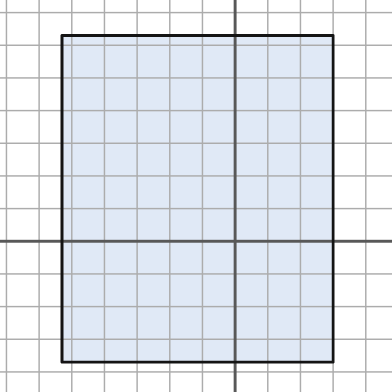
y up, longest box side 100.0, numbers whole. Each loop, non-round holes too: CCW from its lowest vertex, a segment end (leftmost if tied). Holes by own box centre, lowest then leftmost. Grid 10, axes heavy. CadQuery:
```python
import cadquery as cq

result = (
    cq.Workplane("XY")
    .moveTo(-53.0, -37.0)
    .lineTo(30.0, -37.0)
    .lineTo(30.0, 63.0)
    .lineTo(-53.0, 63.0)
    .close()
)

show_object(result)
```